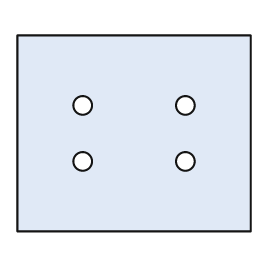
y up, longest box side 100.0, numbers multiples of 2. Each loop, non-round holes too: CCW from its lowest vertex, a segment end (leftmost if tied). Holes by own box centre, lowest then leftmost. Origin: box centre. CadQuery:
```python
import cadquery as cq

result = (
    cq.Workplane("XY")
    .moveTo(-50.0, -42.0)
    .lineTo(50.0, -42.0)
    .lineTo(50.0, 42.0)
    .lineTo(-50.0, 42.0)
    .close()
    .moveTo(-22.0, -12.0)
    .circle(4.0)
    .moveTo(22.0, -12.0)
    .circle(4.0)
    .moveTo(-22.0, 12.0)
    .circle(4.0)
    .moveTo(22.0, 12.0)
    .circle(4.0)
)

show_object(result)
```